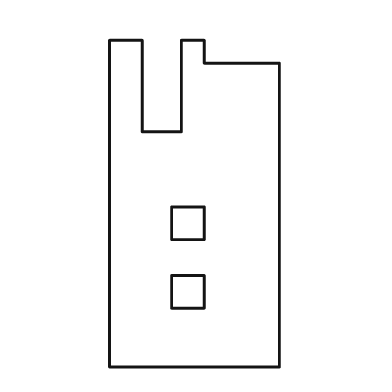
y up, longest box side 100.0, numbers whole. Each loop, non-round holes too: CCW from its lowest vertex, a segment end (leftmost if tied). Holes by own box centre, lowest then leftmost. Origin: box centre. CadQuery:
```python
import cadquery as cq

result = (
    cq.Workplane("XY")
    .moveTo(-26.0, -50.0)
    .lineTo(26.0, -50.0)
    .lineTo(26.0, 43.0)
    .lineTo(3.0, 43.0)
    .lineTo(3.0, 50.0)
    .lineTo(-4.0, 50.0)
    .lineTo(-4.0, 22.0)
    .lineTo(-16.0, 22.0)
    .lineTo(-16.0, 50.0)
    .lineTo(-26.0, 50.0)
    .close()
    .moveTo(-7.0, -32.0)
    .lineTo(3.0, -32.0)
    .lineTo(3.0, -22.0)
    .lineTo(-7.0, -22.0)
    .close()
    .moveTo(-7.0, -11.0)
    .lineTo(3.0, -11.0)
    .lineTo(3.0, -1.0)
    .lineTo(-7.0, -1.0)
    .close()
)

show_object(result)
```